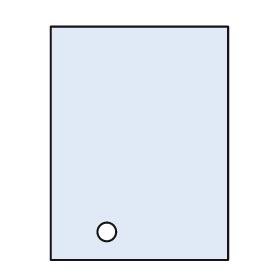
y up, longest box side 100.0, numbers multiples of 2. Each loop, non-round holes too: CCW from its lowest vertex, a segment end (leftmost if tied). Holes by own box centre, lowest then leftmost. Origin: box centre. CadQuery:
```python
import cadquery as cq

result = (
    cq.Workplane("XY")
    .moveTo(-38.0, -50.0)
    .lineTo(38.0, -50.0)
    .lineTo(38.0, 50.0)
    .lineTo(-38.0, 50.0)
    .close()
    .moveTo(-14.0, -38.0)
    .circle(4.0)
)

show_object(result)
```